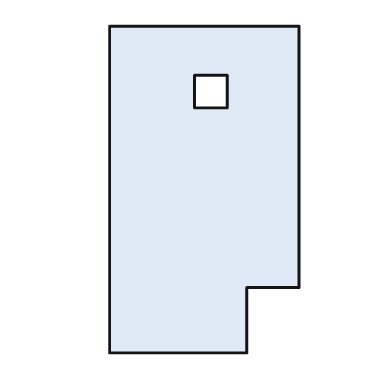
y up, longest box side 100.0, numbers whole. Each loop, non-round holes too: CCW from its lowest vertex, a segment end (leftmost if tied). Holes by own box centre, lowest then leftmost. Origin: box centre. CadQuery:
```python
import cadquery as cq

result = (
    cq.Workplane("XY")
    .moveTo(-29.0, -50.0)
    .lineTo(13.0, -50.0)
    .lineTo(13.0, -30.0)
    .lineTo(29.0, -30.0)
    .lineTo(29.0, 50.0)
    .lineTo(-29.0, 50.0)
    .close()
    .moveTo(-3.0, 25.0)
    .lineTo(7.0, 25.0)
    .lineTo(7.0, 35.0)
    .lineTo(-3.0, 35.0)
    .close()
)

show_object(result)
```